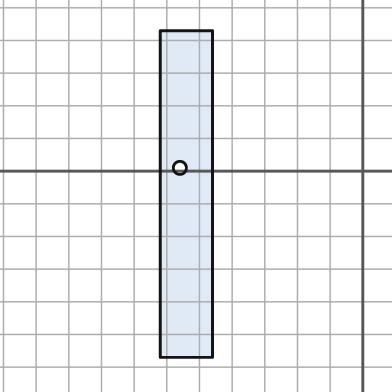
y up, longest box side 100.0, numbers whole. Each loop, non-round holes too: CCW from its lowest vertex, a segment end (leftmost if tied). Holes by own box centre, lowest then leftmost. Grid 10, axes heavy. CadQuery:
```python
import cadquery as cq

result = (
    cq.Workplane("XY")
    .moveTo(-62.0, -57.0)
    .lineTo(-46.0, -57.0)
    .lineTo(-46.0, 43.0)
    .lineTo(-62.0, 43.0)
    .close()
    .moveTo(-56.0, 1.0)
    .circle(2.0)
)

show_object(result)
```